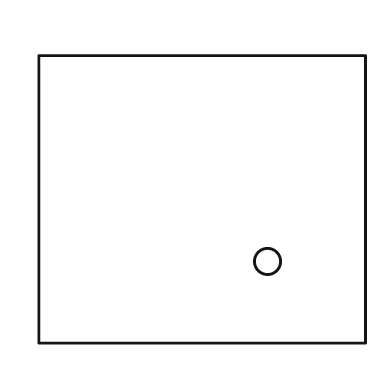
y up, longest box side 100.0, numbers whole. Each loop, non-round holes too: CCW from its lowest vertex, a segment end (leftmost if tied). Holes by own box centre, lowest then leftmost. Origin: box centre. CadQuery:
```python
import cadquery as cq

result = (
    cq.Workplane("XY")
    .moveTo(-50.0, -44.0)
    .lineTo(50.0, -44.0)
    .lineTo(50.0, 44.0)
    .lineTo(-50.0, 44.0)
    .close()
    .moveTo(20.0, -19.0)
    .circle(4.0)
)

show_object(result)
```